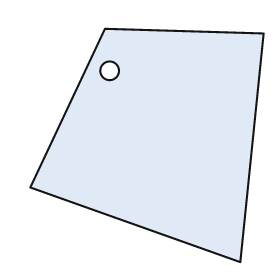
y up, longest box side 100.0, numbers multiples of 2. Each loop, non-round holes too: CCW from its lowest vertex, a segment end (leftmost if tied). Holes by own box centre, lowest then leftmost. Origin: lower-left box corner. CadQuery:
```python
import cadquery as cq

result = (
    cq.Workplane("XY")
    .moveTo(90.0, 0.0)
    .lineTo(100.0, 98.0)
    .lineTo(32.0, 100.0)
    .lineTo(0.0, 32.0)
    .close()
    .moveTo(34.0, 82.0)
    .circle(4.0)
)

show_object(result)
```